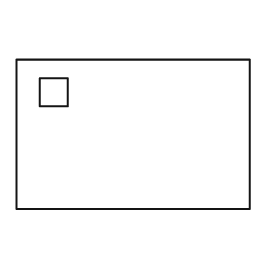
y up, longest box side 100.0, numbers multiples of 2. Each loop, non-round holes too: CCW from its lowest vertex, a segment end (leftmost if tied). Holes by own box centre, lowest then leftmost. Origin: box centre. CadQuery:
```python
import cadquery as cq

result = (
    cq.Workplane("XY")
    .moveTo(-50.0, -32.0)
    .lineTo(50.0, -32.0)
    .lineTo(50.0, 32.0)
    .lineTo(-50.0, 32.0)
    .close()
    .moveTo(-40.0, 12.0)
    .lineTo(-28.0, 12.0)
    .lineTo(-28.0, 24.0)
    .lineTo(-40.0, 24.0)
    .close()
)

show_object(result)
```